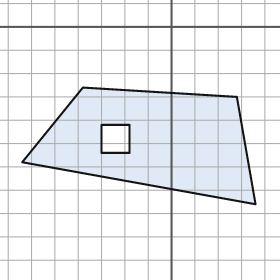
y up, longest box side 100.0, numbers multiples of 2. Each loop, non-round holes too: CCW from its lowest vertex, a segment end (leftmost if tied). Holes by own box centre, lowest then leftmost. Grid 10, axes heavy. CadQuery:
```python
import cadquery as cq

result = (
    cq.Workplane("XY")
    .moveTo(36.0, -76.0)
    .lineTo(28.0, -30.0)
    .lineTo(-38.0, -26.0)
    .lineTo(-64.0, -58.0)
    .close()
    .moveTo(-30.0, -54.0)
    .lineTo(-18.0, -54.0)
    .lineTo(-18.0, -42.0)
    .lineTo(-30.0, -42.0)
    .close()
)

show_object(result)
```